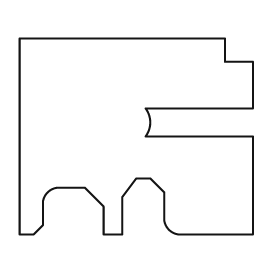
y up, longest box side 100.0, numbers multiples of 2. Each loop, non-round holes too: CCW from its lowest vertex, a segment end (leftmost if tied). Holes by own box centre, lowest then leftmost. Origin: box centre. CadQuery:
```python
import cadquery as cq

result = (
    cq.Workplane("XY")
    .moveTo(-50.0, -42.0)
    .lineTo(-44.0, -42.0)
    .lineTo(-40.0, -38.0)
    .lineTo(-40.0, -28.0)
    .threePointArc((-38.0, -24.0), (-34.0, -22.0))
    .lineTo(-22.0, -22.0)
    .lineTo(-14.0, -30.0)
    .lineTo(-14.0, -42.0)
    .lineTo(-6.0, -42.0)
    .lineTo(-6.0, -26.0)
    .lineTo(0.0, -18.0)
    .lineTo(6.0, -18.0)
    .lineTo(12.0, -24.0)
    .lineTo(12.0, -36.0)
    .threePointArc((14.0, -40.0), (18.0, -42.0))
    .lineTo(50.0, -42.0)
    .lineTo(50.0, 0.0)
    .lineTo(4.0, 0.0)
    .threePointArc((6.0, 6.0), (4.0, 12.0))
    .lineTo(50.0, 12.0)
    .lineTo(50.0, 32.0)
    .lineTo(38.0, 32.0)
    .lineTo(38.0, 42.0)
    .lineTo(-50.0, 42.0)
    .close()
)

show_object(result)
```